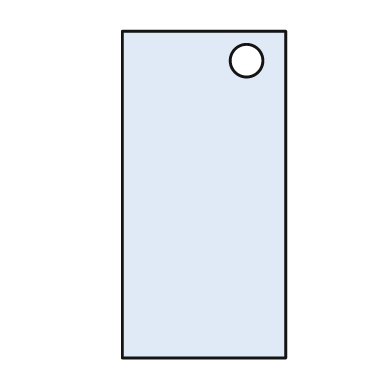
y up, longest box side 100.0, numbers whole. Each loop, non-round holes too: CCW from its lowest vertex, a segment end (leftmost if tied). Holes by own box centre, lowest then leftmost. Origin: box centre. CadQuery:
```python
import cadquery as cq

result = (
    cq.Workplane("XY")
    .moveTo(-25.0, -50.0)
    .lineTo(25.0, -50.0)
    .lineTo(25.0, 50.0)
    .lineTo(-25.0, 50.0)
    .close()
    .moveTo(13.0, 41.0)
    .circle(5.0)
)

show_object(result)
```